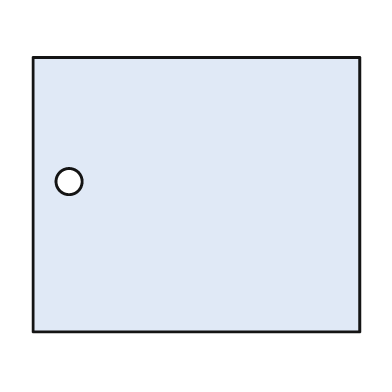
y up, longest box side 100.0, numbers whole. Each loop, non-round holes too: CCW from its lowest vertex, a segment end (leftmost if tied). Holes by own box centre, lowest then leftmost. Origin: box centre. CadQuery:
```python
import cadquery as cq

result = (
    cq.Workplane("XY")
    .moveTo(-50.0, -42.0)
    .lineTo(50.0, -42.0)
    .lineTo(50.0, 42.0)
    .lineTo(-50.0, 42.0)
    .close()
    .moveTo(-39.0, 4.0)
    .circle(4.0)
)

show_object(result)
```